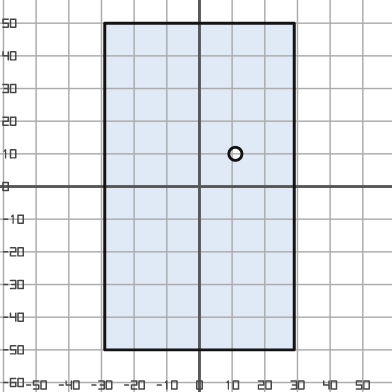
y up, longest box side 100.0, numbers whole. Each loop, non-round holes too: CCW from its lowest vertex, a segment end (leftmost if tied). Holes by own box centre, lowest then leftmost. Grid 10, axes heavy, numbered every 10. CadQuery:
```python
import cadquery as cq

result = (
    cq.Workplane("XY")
    .moveTo(-29.0, -50.0)
    .lineTo(29.0, -50.0)
    .lineTo(29.0, 50.0)
    .lineTo(-29.0, 50.0)
    .close()
    .moveTo(11.0, 10.0)
    .circle(2.0)
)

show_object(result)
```